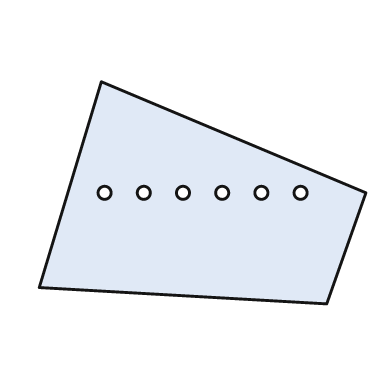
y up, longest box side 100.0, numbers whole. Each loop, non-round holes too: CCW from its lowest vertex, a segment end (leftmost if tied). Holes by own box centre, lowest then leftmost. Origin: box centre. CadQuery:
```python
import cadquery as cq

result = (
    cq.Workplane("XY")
    .moveTo(38.0, -34.0)
    .lineTo(50.0, 0.0)
    .lineTo(-31.0, 34.0)
    .lineTo(-50.0, -29.0)
    .close()
    .moveTo(-30.0, 0.0)
    .circle(2.0)
    .moveTo(-18.0, 0.0)
    .circle(2.0)
    .moveTo(-6.0, 0.0)
    .circle(2.0)
    .moveTo(6.0, 0.0)
    .circle(2.0)
    .moveTo(18.0, 0.0)
    .circle(2.0)
    .moveTo(30.0, 0.0)
    .circle(2.0)
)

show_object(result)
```